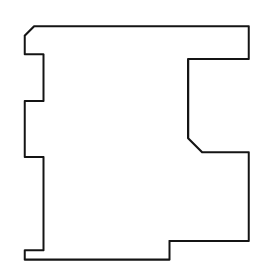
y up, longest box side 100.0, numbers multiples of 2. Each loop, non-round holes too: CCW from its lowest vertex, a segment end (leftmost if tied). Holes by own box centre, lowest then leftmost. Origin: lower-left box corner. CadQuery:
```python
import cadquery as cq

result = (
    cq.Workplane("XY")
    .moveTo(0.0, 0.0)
    .lineTo(62.0, 0.0)
    .lineTo(62.0, 8.0)
    .lineTo(96.0, 8.0)
    .lineTo(96.0, 46.0)
    .lineTo(76.0, 46.0)
    .lineTo(70.0, 52.0)
    .lineTo(70.0, 86.0)
    .lineTo(96.0, 86.0)
    .lineTo(96.0, 100.0)
    .lineTo(4.0, 100.0)
    .lineTo(0.0, 96.0)
    .lineTo(0.0, 88.0)
    .lineTo(8.0, 88.0)
    .lineTo(8.0, 68.0)
    .lineTo(0.0, 68.0)
    .lineTo(0.0, 44.0)
    .lineTo(8.0, 44.0)
    .lineTo(8.0, 4.0)
    .lineTo(0.0, 4.0)
    .close()
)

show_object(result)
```